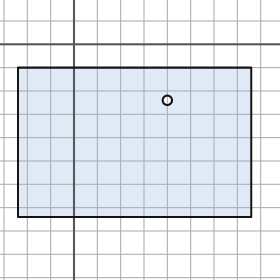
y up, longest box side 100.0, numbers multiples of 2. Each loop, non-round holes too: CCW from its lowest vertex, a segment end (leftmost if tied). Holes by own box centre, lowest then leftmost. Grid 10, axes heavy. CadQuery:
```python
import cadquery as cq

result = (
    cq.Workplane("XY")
    .moveTo(-24.0, -74.0)
    .lineTo(76.0, -74.0)
    .lineTo(76.0, -10.0)
    .lineTo(-24.0, -10.0)
    .close()
    .moveTo(40.0, -24.0)
    .circle(2.0)
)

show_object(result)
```